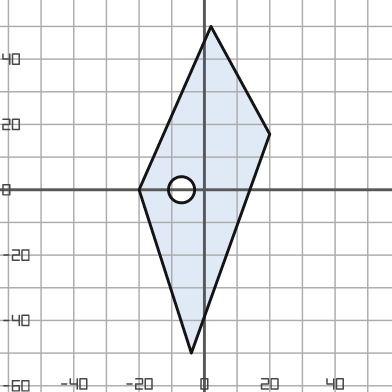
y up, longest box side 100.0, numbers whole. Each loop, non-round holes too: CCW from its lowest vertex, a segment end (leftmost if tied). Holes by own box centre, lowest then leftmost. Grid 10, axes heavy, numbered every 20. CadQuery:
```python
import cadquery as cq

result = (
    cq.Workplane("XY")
    .moveTo(-4.0, -50.0)
    .lineTo(20.0, 17.0)
    .lineTo(2.0, 50.0)
    .lineTo(-20.0, 0.0)
    .close()
    .moveTo(-7.0, 0.0)
    .circle(4.0)
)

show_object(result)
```